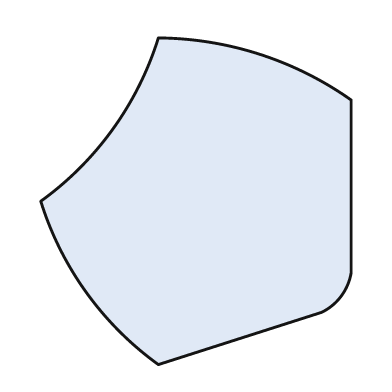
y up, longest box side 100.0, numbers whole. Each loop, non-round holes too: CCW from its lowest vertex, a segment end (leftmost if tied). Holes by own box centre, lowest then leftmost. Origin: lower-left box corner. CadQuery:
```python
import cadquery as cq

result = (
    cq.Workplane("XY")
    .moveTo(36.0, 0.0)
    .lineTo(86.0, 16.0)
    .threePointArc((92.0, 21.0), (95.0, 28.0))
    .lineTo(95.0, 81.0)
    .threePointArc((67.0, 95.0), (36.0, 100.0))
    .threePointArc((22.0, 72.0), (0.0, 50.0))
    .threePointArc((14.0, 22.0), (36.0, 0.0))
    .close()
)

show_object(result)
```